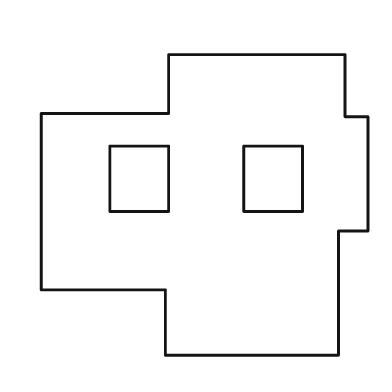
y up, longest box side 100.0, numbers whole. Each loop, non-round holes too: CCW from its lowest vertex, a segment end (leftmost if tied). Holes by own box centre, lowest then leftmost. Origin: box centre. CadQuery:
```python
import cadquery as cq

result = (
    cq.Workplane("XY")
    .moveTo(-12.0, -46.0)
    .lineTo(41.0, -46.0)
    .lineTo(41.0, -8.0)
    .lineTo(50.0, -8.0)
    .lineTo(50.0, 27.0)
    .lineTo(43.0, 27.0)
    .lineTo(43.0, 46.0)
    .lineTo(-11.0, 46.0)
    .lineTo(-11.0, 28.0)
    .lineTo(-50.0, 28.0)
    .lineTo(-50.0, -26.0)
    .lineTo(-12.0, -26.0)
    .close()
    .moveTo(-29.0, -2.0)
    .lineTo(-11.0, -2.0)
    .lineTo(-11.0, 18.0)
    .lineTo(-29.0, 18.0)
    .close()
    .moveTo(12.0, -2.0)
    .lineTo(30.0, -2.0)
    .lineTo(30.0, 18.0)
    .lineTo(12.0, 18.0)
    .close()
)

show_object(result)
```